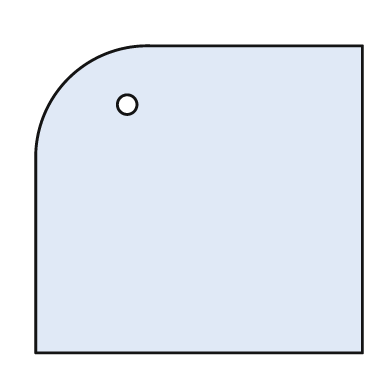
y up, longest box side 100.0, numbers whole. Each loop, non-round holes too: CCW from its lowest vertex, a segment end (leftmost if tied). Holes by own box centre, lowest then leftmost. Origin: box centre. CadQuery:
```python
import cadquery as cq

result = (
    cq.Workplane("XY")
    .moveTo(-50.0, -47.0)
    .lineTo(50.0, -47.0)
    .lineTo(50.0, 47.0)
    .lineTo(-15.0, 47.0)
    .threePointArc((-40.0, 37.0), (-50.0, 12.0))
    .close()
    .moveTo(-22.0, 29.0)
    .circle(3.0)
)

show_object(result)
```